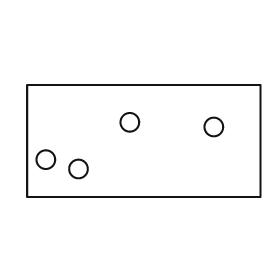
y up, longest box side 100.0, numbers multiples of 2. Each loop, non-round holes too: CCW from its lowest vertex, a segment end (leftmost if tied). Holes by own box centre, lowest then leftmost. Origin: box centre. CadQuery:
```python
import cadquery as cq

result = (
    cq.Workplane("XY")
    .moveTo(-50.0, -24.0)
    .lineTo(50.0, -24.0)
    .lineTo(50.0, 24.0)
    .lineTo(-50.0, 24.0)
    .close()
    .moveTo(-28.0, -12.0)
    .circle(4.0)
    .moveTo(-42.0, -8.0)
    .circle(4.0)
    .moveTo(30.0, 6.0)
    .circle(4.0)
    .moveTo(-6.0, 8.0)
    .circle(4.0)
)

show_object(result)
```